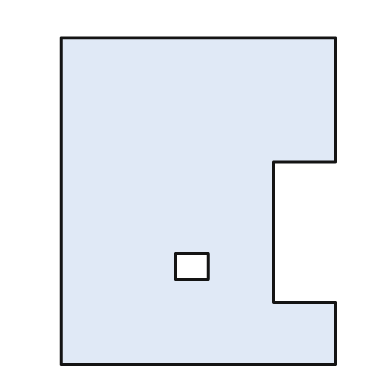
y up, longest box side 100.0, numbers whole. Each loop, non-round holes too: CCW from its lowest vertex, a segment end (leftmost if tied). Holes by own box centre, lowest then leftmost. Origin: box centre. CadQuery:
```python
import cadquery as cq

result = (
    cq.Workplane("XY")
    .moveTo(-42.0, -50.0)
    .lineTo(42.0, -50.0)
    .lineTo(42.0, -31.0)
    .lineTo(23.0, -31.0)
    .lineTo(23.0, 12.0)
    .lineTo(42.0, 12.0)
    .lineTo(42.0, 50.0)
    .lineTo(-42.0, 50.0)
    .close()
    .moveTo(-7.0, -24.0)
    .lineTo(3.0, -24.0)
    .lineTo(3.0, -16.0)
    .lineTo(-7.0, -16.0)
    .close()
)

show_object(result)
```